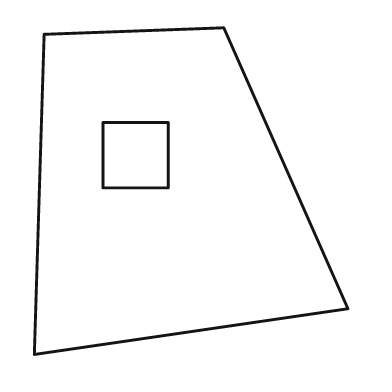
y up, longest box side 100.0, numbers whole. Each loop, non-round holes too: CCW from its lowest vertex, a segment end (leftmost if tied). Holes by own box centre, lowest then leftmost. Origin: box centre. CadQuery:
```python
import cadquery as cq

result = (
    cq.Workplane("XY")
    .moveTo(-48.0, -50.0)
    .lineTo(48.0, -36.0)
    .lineTo(10.0, 50.0)
    .lineTo(-45.0, 48.0)
    .close()
    .moveTo(-27.0, 1.0)
    .lineTo(-7.0, 1.0)
    .lineTo(-7.0, 21.0)
    .lineTo(-27.0, 21.0)
    .close()
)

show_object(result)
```